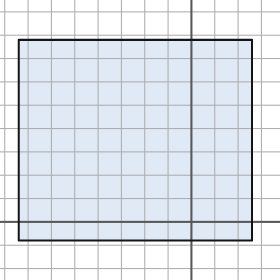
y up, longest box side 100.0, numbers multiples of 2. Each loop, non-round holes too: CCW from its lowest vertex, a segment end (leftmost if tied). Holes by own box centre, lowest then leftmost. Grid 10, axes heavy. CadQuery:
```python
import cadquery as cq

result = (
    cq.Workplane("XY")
    .moveTo(-74.0, -8.0)
    .lineTo(26.0, -8.0)
    .lineTo(26.0, 78.0)
    .lineTo(-74.0, 78.0)
    .close()
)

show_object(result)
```